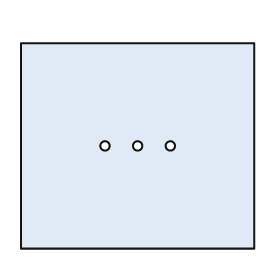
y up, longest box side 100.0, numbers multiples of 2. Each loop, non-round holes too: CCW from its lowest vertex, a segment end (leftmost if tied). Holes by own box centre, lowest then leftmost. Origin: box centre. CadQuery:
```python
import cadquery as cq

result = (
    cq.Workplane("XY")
    .moveTo(-50.0, -44.0)
    .lineTo(50.0, -44.0)
    .lineTo(50.0, 44.0)
    .lineTo(-50.0, 44.0)
    .close()
    .moveTo(-14.0, 0.0)
    .circle(2.0)
    .moveTo(0.0, 0.0)
    .circle(2.0)
    .moveTo(14.0, 0.0)
    .circle(2.0)
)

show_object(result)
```